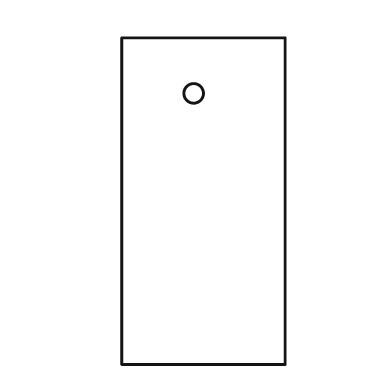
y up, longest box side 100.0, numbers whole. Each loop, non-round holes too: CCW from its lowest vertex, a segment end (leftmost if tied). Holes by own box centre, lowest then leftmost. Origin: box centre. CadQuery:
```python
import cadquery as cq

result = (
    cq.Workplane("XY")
    .moveTo(-25.0, -50.0)
    .lineTo(25.0, -50.0)
    .lineTo(25.0, 50.0)
    .lineTo(-25.0, 50.0)
    .close()
    .moveTo(-3.0, 33.0)
    .circle(3.0)
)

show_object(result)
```